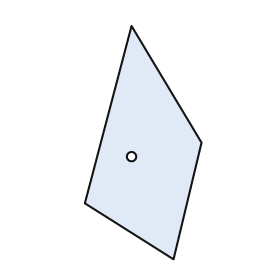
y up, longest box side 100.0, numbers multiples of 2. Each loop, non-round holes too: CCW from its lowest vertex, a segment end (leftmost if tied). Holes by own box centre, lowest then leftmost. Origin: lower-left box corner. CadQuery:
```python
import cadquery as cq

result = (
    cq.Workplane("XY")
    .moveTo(38.0, 0.0)
    .lineTo(50.0, 50.0)
    .lineTo(20.0, 100.0)
    .lineTo(0.0, 24.0)
    .close()
    .moveTo(20.0, 44.0)
    .circle(2.0)
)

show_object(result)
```